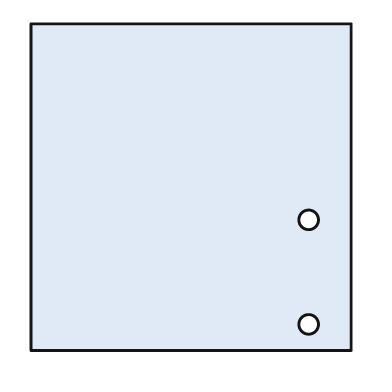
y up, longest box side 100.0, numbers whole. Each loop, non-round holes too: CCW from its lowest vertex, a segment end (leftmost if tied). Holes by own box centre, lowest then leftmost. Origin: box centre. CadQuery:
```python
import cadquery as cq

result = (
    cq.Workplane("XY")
    .moveTo(-49.0, -50.0)
    .lineTo(49.0, -50.0)
    .lineTo(49.0, 50.0)
    .lineTo(-49.0, 50.0)
    .close()
    .moveTo(36.0, -42.0)
    .circle(3.0)
    .moveTo(36.0, -10.0)
    .circle(3.0)
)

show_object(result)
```